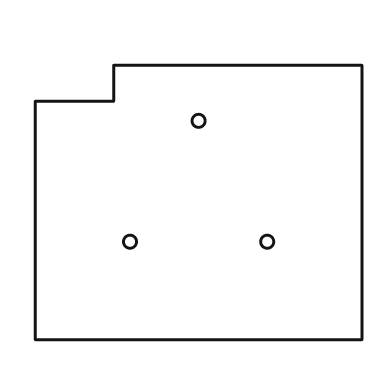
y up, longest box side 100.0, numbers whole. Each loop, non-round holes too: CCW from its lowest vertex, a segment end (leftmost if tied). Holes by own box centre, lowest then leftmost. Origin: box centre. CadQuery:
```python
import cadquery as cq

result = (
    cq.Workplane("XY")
    .moveTo(-50.0, -42.0)
    .lineTo(50.0, -42.0)
    .lineTo(50.0, 42.0)
    .lineTo(-26.0, 42.0)
    .lineTo(-26.0, 31.0)
    .lineTo(-50.0, 31.0)
    .close()
    .moveTo(-21.0, -12.0)
    .circle(2.0)
    .moveTo(21.0, -12.0)
    .circle(2.0)
    .moveTo(0.0, 25.0)
    .circle(2.0)
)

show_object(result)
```